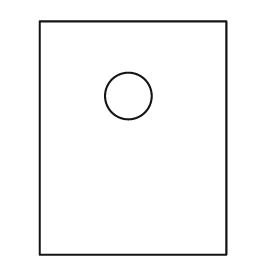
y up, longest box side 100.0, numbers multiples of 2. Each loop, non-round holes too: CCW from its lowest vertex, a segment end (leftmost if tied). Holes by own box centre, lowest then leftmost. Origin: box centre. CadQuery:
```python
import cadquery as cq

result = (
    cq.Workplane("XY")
    .moveTo(-40.0, -50.0)
    .lineTo(40.0, -50.0)
    .lineTo(40.0, 50.0)
    .lineTo(-40.0, 50.0)
    .close()
    .moveTo(-2.0, 18.0)
    .circle(10.0)
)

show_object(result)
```